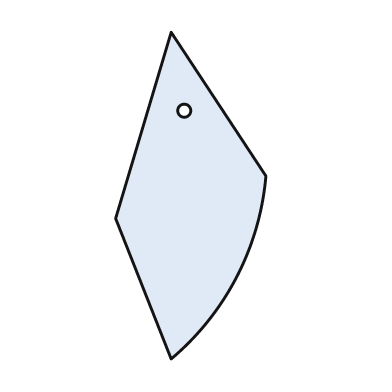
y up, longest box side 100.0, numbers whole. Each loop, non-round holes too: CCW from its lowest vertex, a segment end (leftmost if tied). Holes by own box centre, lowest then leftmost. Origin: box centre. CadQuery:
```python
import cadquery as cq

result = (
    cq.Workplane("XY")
    .moveTo(-6.0, -50.0)
    .threePointArc((14.0, -25.0), (23.0, 6.0))
    .lineTo(-6.0, 50.0)
    .lineTo(-23.0, -7.0)
    .close()
    .moveTo(-2.0, 26.0)
    .circle(2.0)
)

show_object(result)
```